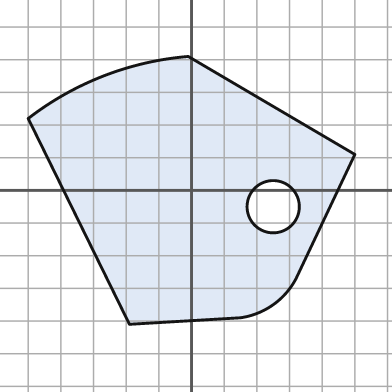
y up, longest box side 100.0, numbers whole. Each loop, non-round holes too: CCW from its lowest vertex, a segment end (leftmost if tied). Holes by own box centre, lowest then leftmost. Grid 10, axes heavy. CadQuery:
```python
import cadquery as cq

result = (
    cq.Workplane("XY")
    .moveTo(-19.0, -41.0)
    .lineTo(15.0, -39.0)
    .threePointArc((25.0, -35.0), (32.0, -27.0))
    .lineTo(50.0, 11.0)
    .lineTo(-1.0, 41.0)
    .threePointArc((-27.0, 35.0), (-50.0, 22.0))
    .close()
    .moveTo(25.0, -5.0)
    .circle(8.0)
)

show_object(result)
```